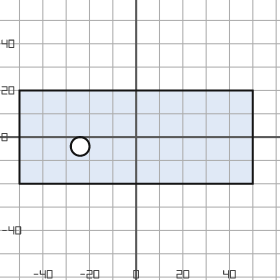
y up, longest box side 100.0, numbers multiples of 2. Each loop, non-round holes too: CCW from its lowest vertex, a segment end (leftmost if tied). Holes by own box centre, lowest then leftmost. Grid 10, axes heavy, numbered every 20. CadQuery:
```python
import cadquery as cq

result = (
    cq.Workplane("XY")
    .moveTo(-50.0, -20.0)
    .lineTo(50.0, -20.0)
    .lineTo(50.0, 20.0)
    .lineTo(-50.0, 20.0)
    .close()
    .moveTo(-24.0, -4.0)
    .circle(4.0)
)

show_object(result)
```